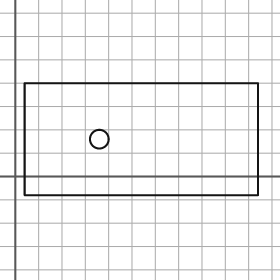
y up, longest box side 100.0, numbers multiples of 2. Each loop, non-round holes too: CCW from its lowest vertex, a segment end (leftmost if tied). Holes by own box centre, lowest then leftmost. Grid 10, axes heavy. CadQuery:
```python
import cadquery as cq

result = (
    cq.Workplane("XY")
    .moveTo(4.0, -8.0)
    .lineTo(104.0, -8.0)
    .lineTo(104.0, 40.0)
    .lineTo(4.0, 40.0)
    .close()
    .moveTo(36.0, 16.0)
    .circle(4.0)
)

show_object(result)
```